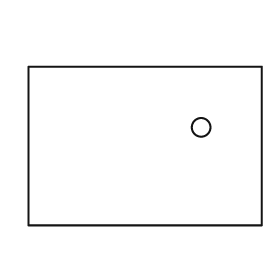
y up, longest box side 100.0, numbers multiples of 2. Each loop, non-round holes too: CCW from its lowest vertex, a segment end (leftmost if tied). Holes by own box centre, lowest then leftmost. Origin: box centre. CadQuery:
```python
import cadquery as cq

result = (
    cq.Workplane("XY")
    .moveTo(-50.0, -34.0)
    .lineTo(50.0, -34.0)
    .lineTo(50.0, 34.0)
    .lineTo(-50.0, 34.0)
    .close()
    .moveTo(24.0, 8.0)
    .circle(4.0)
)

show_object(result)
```